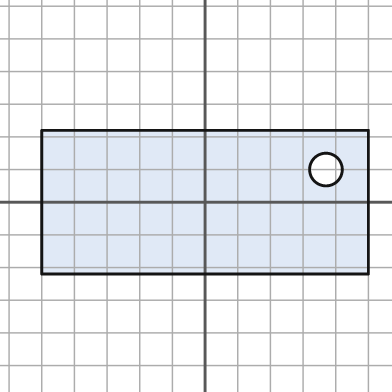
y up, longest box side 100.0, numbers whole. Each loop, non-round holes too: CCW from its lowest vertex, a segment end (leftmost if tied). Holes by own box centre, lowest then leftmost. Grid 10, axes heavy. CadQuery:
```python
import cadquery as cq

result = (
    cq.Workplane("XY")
    .moveTo(-50.0, -22.0)
    .lineTo(50.0, -22.0)
    .lineTo(50.0, 22.0)
    .lineTo(-50.0, 22.0)
    .close()
    .moveTo(37.0, 10.0)
    .circle(5.0)
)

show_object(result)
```